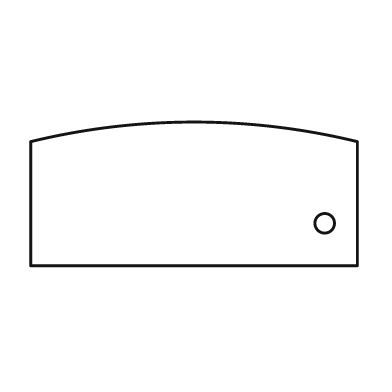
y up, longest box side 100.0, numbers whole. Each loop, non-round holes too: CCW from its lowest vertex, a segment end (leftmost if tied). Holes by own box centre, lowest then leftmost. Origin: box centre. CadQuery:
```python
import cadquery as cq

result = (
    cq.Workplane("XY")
    .moveTo(-50.0, -22.0)
    .lineTo(50.0, -22.0)
    .lineTo(50.0, 16.0)
    .threePointArc((0.0, 22.0), (-50.0, 16.0))
    .close()
    .moveTo(40.0, -9.0)
    .circle(3.0)
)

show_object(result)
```